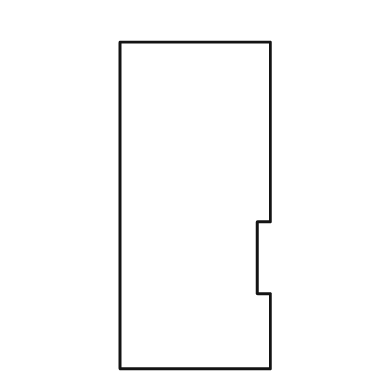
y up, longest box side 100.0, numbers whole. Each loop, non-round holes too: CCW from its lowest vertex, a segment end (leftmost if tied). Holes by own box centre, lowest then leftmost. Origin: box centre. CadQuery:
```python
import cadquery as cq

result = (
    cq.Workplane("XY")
    .moveTo(-23.0, -50.0)
    .lineTo(23.0, -50.0)
    .lineTo(23.0, -27.0)
    .lineTo(19.0, -27.0)
    .lineTo(19.0, -5.0)
    .lineTo(23.0, -5.0)
    .lineTo(23.0, 50.0)
    .lineTo(-23.0, 50.0)
    .close()
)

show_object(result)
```